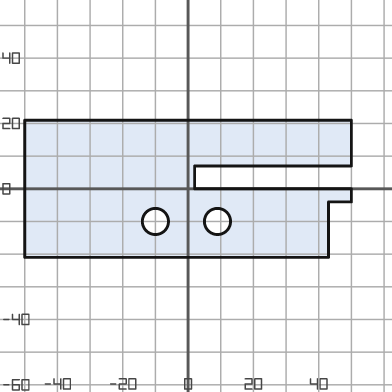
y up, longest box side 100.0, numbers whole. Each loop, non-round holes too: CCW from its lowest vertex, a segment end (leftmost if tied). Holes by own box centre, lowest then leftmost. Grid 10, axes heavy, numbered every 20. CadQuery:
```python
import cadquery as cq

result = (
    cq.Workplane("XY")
    .moveTo(-50.0, -21.0)
    .lineTo(43.0, -21.0)
    .lineTo(43.0, -4.0)
    .lineTo(50.0, -4.0)
    .lineTo(50.0, 0.0)
    .lineTo(2.0, 0.0)
    .lineTo(2.0, 7.0)
    .lineTo(50.0, 7.0)
    .lineTo(50.0, 21.0)
    .lineTo(-50.0, 21.0)
    .close()
    .moveTo(-10.0, -10.0)
    .circle(4.0)
    .moveTo(9.0, -10.0)
    .circle(4.0)
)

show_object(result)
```